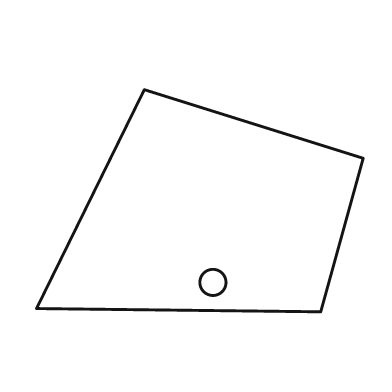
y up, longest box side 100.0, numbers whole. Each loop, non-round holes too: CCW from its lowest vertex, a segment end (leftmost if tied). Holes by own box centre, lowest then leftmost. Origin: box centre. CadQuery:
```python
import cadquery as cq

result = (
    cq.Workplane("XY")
    .moveTo(37.0, -34.0)
    .lineTo(50.0, 13.0)
    .lineTo(-17.0, 34.0)
    .lineTo(-50.0, -33.0)
    .close()
    .moveTo(4.0, -25.0)
    .circle(4.0)
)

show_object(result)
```